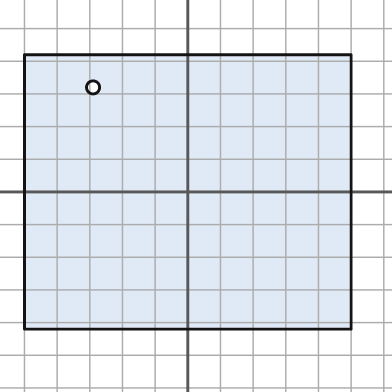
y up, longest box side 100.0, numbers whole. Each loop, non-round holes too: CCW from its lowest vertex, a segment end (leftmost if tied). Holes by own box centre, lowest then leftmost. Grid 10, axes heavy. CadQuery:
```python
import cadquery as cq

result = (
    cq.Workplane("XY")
    .moveTo(-50.0, -42.0)
    .lineTo(50.0, -42.0)
    .lineTo(50.0, 42.0)
    .lineTo(-50.0, 42.0)
    .close()
    .moveTo(-29.0, 32.0)
    .circle(2.0)
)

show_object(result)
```